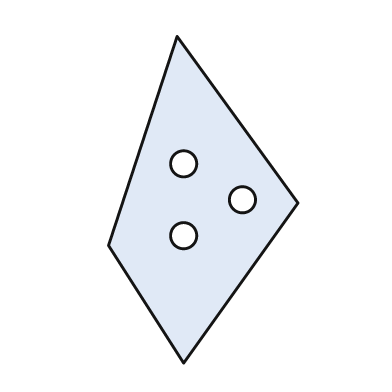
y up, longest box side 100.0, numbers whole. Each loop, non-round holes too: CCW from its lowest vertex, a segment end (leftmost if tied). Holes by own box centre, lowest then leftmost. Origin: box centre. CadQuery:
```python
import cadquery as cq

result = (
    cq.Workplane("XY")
    .moveTo(-6.0, -50.0)
    .lineTo(29.0, -1.0)
    .lineTo(-8.0, 50.0)
    .lineTo(-29.0, -14.0)
    .close()
    .moveTo(-6.0, -11.0)
    .circle(4.0)
    .moveTo(12.0, 0.0)
    .circle(4.0)
    .moveTo(-6.0, 11.0)
    .circle(4.0)
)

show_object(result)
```